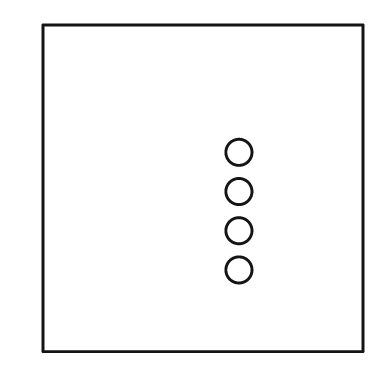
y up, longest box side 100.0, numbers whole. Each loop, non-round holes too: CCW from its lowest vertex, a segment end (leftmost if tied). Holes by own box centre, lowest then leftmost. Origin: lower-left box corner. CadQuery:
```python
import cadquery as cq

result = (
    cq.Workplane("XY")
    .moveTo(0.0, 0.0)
    .lineTo(98.0, 0.0)
    .lineTo(98.0, 100.0)
    .lineTo(0.0, 100.0)
    .close()
    .moveTo(60.0, 25.0)
    .circle(4.0)
    .moveTo(60.0, 37.0)
    .circle(4.0)
    .moveTo(60.0, 49.0)
    .circle(4.0)
    .moveTo(60.0, 61.0)
    .circle(4.0)
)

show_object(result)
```